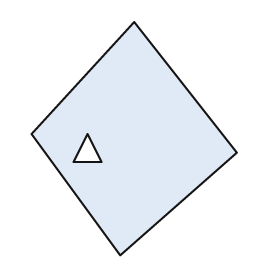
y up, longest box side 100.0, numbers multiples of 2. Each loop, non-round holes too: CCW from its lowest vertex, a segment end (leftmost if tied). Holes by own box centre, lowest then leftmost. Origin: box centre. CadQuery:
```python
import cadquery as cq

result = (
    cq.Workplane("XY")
    .moveTo(-6.0, -50.0)
    .lineTo(44.0, -6.0)
    .lineTo(0.0, 50.0)
    .lineTo(-44.0, 2.0)
    .close()
    .moveTo(-26.0, -10.0)
    .lineTo(-14.0, -10.0)
    .lineTo(-20.0, 2.0)
    .close()
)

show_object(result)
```